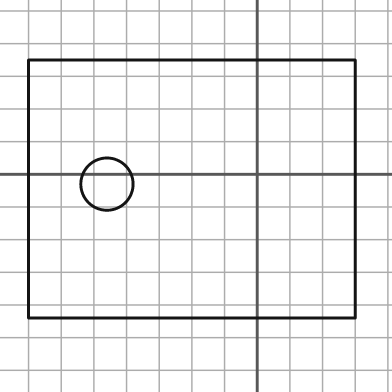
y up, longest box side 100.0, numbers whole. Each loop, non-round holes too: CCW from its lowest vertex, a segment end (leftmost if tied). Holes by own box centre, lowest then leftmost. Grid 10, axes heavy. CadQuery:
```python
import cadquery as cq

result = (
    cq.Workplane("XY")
    .moveTo(-70.0, -44.0)
    .lineTo(30.0, -44.0)
    .lineTo(30.0, 35.0)
    .lineTo(-70.0, 35.0)
    .close()
    .moveTo(-46.0, -3.0)
    .circle(8.0)
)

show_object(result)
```